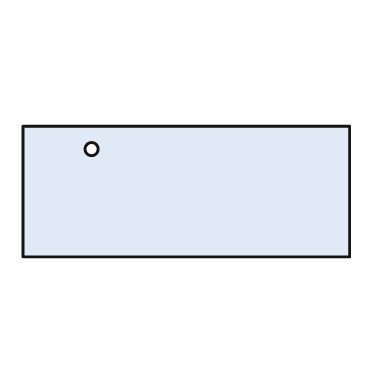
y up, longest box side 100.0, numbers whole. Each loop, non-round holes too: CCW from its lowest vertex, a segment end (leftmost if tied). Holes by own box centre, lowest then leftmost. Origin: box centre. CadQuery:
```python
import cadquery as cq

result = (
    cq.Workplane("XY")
    .moveTo(-50.0, -20.0)
    .lineTo(50.0, -20.0)
    .lineTo(50.0, 20.0)
    .lineTo(-50.0, 20.0)
    .close()
    .moveTo(-29.0, 13.0)
    .circle(2.0)
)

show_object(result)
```